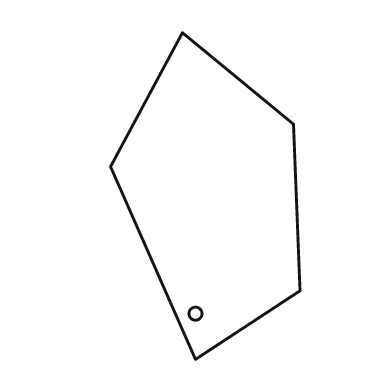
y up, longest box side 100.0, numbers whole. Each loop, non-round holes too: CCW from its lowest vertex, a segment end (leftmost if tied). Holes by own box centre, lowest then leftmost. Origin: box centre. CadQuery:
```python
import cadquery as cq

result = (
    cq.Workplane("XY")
    .moveTo(-3.0, -50.0)
    .lineTo(29.0, -29.0)
    .lineTo(27.0, 22.0)
    .lineTo(-7.0, 50.0)
    .lineTo(-29.0, 9.0)
    .close()
    .moveTo(-3.0, -36.0)
    .circle(2.0)
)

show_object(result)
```